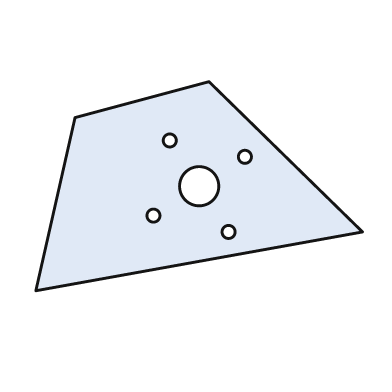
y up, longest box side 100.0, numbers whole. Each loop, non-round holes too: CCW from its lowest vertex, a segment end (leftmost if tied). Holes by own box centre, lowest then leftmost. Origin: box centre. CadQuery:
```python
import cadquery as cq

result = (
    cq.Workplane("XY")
    .moveTo(-50.0, -32.0)
    .lineTo(50.0, -14.0)
    .lineTo(3.0, 32.0)
    .lineTo(-38.0, 21.0)
    .close()
    .moveTo(9.0, -14.0)
    .circle(2.0)
    .moveTo(-14.0, -9.0)
    .circle(2.0)
    .moveTo(0.0, 0.0)
    .circle(6.0)
    .moveTo(14.0, 9.0)
    .circle(2.0)
    .moveTo(-9.0, 14.0)
    .circle(2.0)
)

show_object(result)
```